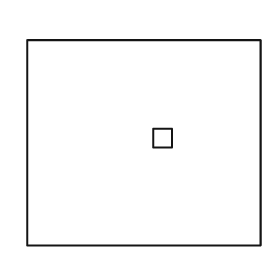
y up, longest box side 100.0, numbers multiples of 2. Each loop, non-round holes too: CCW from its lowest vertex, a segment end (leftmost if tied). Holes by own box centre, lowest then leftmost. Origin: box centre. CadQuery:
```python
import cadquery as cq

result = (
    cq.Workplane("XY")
    .moveTo(-50.0, -44.0)
    .lineTo(50.0, -44.0)
    .lineTo(50.0, 44.0)
    .lineTo(-50.0, 44.0)
    .close()
    .moveTo(4.0, -2.0)
    .lineTo(12.0, -2.0)
    .lineTo(12.0, 6.0)
    .lineTo(4.0, 6.0)
    .close()
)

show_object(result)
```